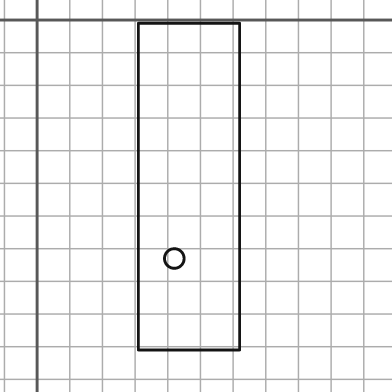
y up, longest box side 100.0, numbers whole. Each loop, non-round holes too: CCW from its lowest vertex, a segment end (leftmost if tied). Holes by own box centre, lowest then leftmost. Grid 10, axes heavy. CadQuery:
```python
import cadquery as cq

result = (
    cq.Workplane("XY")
    .moveTo(31.0, -101.0)
    .lineTo(62.0, -101.0)
    .lineTo(62.0, -1.0)
    .lineTo(31.0, -1.0)
    .close()
    .moveTo(42.0, -73.0)
    .circle(3.0)
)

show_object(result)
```